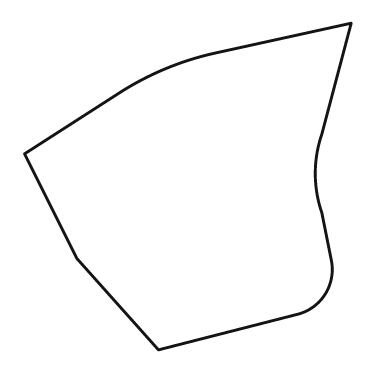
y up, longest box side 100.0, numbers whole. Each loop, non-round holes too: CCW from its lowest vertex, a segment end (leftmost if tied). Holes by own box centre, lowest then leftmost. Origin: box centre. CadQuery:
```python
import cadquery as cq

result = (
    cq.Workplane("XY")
    .moveTo(-9.0, -50.0)
    .lineTo(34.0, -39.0)
    .threePointArc((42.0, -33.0), (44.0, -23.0))
    .lineTo(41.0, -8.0)
    .threePointArc((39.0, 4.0), (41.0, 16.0))
    .lineTo(50.0, 50.0)
    .lineTo(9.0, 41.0)
    .threePointArc((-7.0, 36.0), (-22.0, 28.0))
    .lineTo(-50.0, 10.0)
    .lineTo(-34.0, -22.0)
    .close()
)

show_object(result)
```